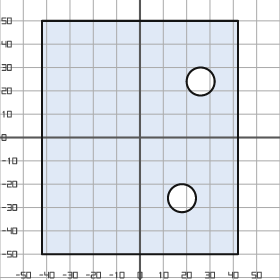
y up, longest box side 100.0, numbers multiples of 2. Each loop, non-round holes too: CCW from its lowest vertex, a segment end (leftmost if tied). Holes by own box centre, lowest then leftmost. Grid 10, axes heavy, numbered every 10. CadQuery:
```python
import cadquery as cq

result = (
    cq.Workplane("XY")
    .moveTo(-42.0, -50.0)
    .lineTo(42.0, -50.0)
    .lineTo(42.0, 50.0)
    .lineTo(-42.0, 50.0)
    .close()
    .moveTo(18.0, -26.0)
    .circle(6.0)
    .moveTo(26.0, 24.0)
    .circle(6.0)
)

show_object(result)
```